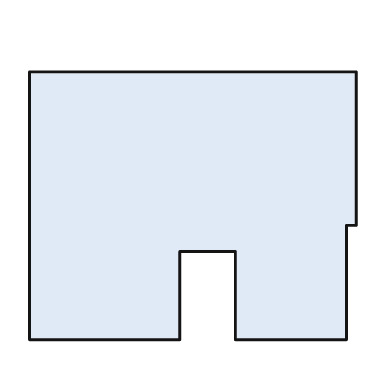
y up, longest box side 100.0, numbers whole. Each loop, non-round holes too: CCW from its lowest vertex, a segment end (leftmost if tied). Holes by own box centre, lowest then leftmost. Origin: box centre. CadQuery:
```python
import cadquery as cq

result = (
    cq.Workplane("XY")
    .moveTo(-50.0, -41.0)
    .lineTo(-4.0, -41.0)
    .lineTo(-4.0, -14.0)
    .lineTo(13.0, -14.0)
    .lineTo(13.0, -41.0)
    .lineTo(47.0, -41.0)
    .lineTo(47.0, -6.0)
    .lineTo(50.0, -6.0)
    .lineTo(50.0, 41.0)
    .lineTo(-50.0, 41.0)
    .close()
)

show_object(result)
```